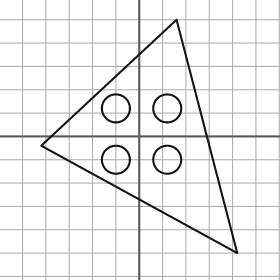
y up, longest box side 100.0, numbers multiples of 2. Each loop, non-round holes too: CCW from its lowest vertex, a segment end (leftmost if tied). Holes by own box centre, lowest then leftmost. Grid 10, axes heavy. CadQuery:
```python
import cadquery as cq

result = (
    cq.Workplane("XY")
    .moveTo(42.0, -50.0)
    .lineTo(16.0, 50.0)
    .lineTo(-42.0, -4.0)
    .close()
    .moveTo(-10.0, -10.0)
    .circle(6.0)
    .moveTo(12.0, -10.0)
    .circle(6.0)
    .moveTo(-10.0, 12.0)
    .circle(6.0)
    .moveTo(12.0, 12.0)
    .circle(6.0)
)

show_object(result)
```